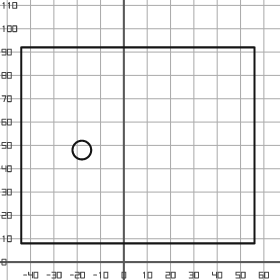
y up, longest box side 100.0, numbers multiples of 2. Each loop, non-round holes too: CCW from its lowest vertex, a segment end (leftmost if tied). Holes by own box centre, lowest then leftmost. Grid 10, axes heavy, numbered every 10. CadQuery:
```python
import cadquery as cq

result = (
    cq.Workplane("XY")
    .moveTo(-44.0, 8.0)
    .lineTo(56.0, 8.0)
    .lineTo(56.0, 92.0)
    .lineTo(-44.0, 92.0)
    .close()
    .moveTo(-18.0, 48.0)
    .circle(4.0)
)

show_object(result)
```